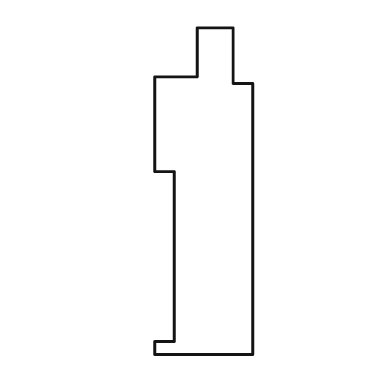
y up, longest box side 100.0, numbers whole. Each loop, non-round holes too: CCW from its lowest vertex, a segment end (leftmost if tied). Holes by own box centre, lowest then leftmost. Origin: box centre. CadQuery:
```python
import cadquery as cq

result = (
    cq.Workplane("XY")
    .moveTo(-15.0, -50.0)
    .lineTo(15.0, -50.0)
    .lineTo(15.0, 33.0)
    .lineTo(9.0, 33.0)
    .lineTo(9.0, 50.0)
    .lineTo(-2.0, 50.0)
    .lineTo(-2.0, 35.0)
    .lineTo(-15.0, 35.0)
    .lineTo(-15.0, 6.0)
    .lineTo(-9.0, 6.0)
    .lineTo(-9.0, -46.0)
    .lineTo(-15.0, -46.0)
    .close()
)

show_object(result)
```